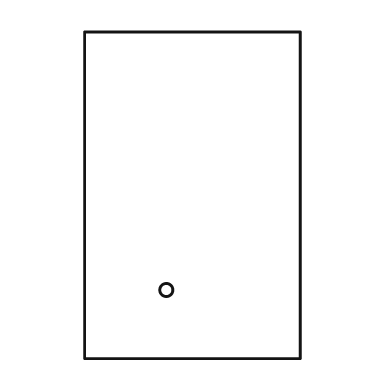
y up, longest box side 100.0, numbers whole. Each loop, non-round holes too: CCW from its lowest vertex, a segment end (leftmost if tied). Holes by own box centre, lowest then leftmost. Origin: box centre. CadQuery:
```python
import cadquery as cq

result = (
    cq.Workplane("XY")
    .moveTo(-33.0, -50.0)
    .lineTo(33.0, -50.0)
    .lineTo(33.0, 50.0)
    .lineTo(-33.0, 50.0)
    .close()
    .moveTo(-8.0, -29.0)
    .circle(2.0)
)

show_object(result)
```